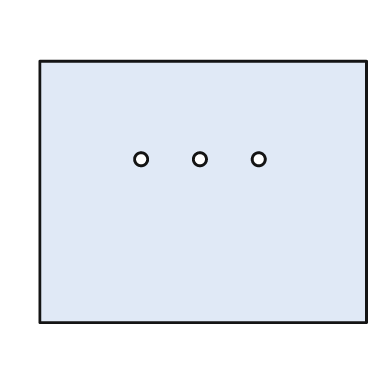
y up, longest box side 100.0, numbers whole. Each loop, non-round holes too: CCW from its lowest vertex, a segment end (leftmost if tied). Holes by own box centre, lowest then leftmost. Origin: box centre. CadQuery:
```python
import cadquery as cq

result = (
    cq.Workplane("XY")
    .moveTo(-50.0, -40.0)
    .lineTo(50.0, -40.0)
    .lineTo(50.0, 40.0)
    .lineTo(-50.0, 40.0)
    .close()
    .moveTo(-19.0, 10.0)
    .circle(2.0)
    .moveTo(-1.0, 10.0)
    .circle(2.0)
    .moveTo(17.0, 10.0)
    .circle(2.0)
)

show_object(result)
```